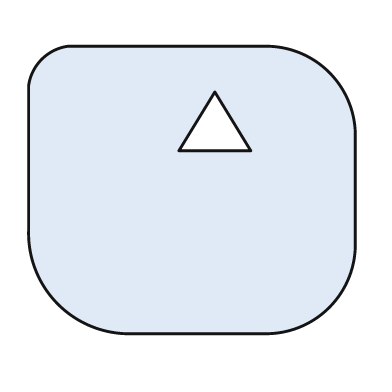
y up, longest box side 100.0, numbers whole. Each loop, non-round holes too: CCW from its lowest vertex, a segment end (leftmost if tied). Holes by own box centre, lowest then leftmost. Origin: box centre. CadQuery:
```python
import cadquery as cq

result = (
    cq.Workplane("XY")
    .moveTo(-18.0, -44.0)
    .lineTo(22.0, -44.0)
    .threePointArc((42.0, -36.0), (50.0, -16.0))
    .lineTo(50.0, 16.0)
    .threePointArc((42.0, 36.0), (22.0, 44.0))
    .lineTo(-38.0, 44.0)
    .threePointArc((-46.0, 40.0), (-50.0, 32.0))
    .lineTo(-50.0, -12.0)
    .threePointArc((-41.0, -35.0), (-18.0, -44.0))
    .close()
    .moveTo(-4.0, 12.0)
    .lineTo(18.0, 12.0)
    .lineTo(7.0, 30.0)
    .close()
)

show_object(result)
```